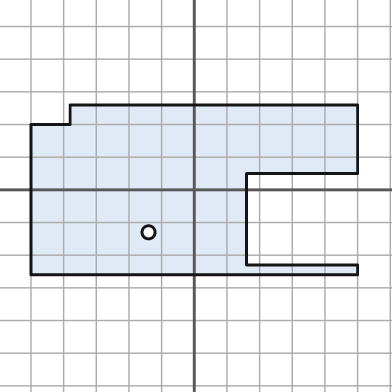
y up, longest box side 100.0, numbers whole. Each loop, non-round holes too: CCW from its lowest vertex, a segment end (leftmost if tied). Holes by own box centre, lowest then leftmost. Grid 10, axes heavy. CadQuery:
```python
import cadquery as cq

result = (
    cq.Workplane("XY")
    .moveTo(-50.0, -26.0)
    .lineTo(50.0, -26.0)
    .lineTo(50.0, -23.0)
    .lineTo(16.0, -23.0)
    .lineTo(16.0, 5.0)
    .lineTo(50.0, 5.0)
    .lineTo(50.0, 26.0)
    .lineTo(-38.0, 26.0)
    .lineTo(-38.0, 20.0)
    .lineTo(-50.0, 20.0)
    .close()
    .moveTo(-14.0, -13.0)
    .circle(2.0)
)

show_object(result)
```